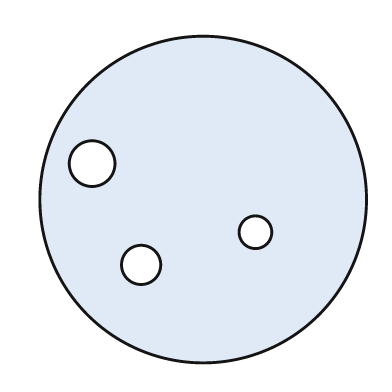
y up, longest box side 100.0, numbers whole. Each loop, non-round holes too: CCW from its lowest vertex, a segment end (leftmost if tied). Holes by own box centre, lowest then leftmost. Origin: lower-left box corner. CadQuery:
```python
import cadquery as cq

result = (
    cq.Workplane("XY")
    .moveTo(50.0, 50.0)
    .circle(50.0)
    .moveTo(31.0, 30.0)
    .circle(6.0)
    .moveTo(66.0, 40.0)
    .circle(5.0)
    .moveTo(16.0, 61.0)
    .circle(7.0)
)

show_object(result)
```